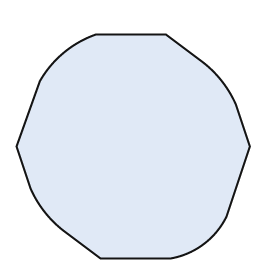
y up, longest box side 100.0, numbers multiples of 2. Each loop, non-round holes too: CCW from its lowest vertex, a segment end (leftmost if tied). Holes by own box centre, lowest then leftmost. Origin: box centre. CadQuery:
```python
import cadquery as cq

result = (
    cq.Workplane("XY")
    .moveTo(-14.0, -48.0)
    .lineTo(16.0, -48.0)
    .threePointArc((30.0, -42.0), (40.0, -30.0))
    .lineTo(50.0, 0.0)
    .lineTo(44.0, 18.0)
    .threePointArc((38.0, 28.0), (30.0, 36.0))
    .lineTo(14.0, 48.0)
    .lineTo(-16.0, 48.0)
    .threePointArc((-30.0, 40.0), (-40.0, 28.0))
    .lineTo(-50.0, 0.0)
    .lineTo(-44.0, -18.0)
    .threePointArc((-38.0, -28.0), (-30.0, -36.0))
    .close()
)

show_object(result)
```